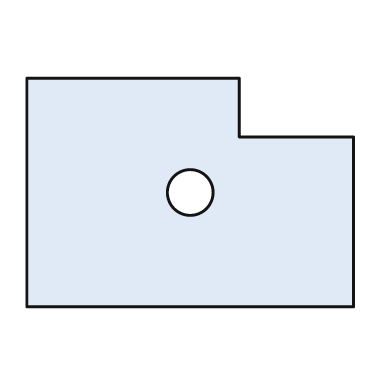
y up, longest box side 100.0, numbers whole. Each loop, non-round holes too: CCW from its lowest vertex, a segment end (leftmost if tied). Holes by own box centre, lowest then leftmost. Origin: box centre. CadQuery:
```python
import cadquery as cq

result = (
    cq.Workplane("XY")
    .moveTo(-50.0, -35.0)
    .lineTo(50.0, -35.0)
    .lineTo(50.0, 17.0)
    .lineTo(15.0, 17.0)
    .lineTo(15.0, 35.0)
    .lineTo(-50.0, 35.0)
    .close()
    .moveTo(0.0, 0.0)
    .circle(7.0)
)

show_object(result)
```